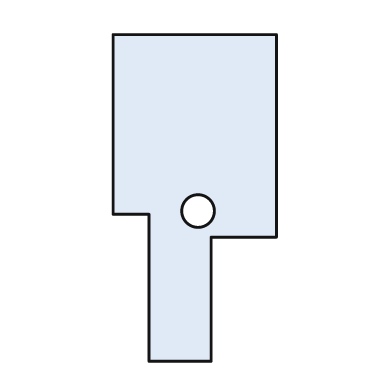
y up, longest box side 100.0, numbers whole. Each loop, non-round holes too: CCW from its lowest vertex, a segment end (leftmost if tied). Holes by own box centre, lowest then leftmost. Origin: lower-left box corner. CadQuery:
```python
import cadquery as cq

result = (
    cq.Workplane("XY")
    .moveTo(11.0, 0.0)
    .lineTo(30.0, 0.0)
    .lineTo(30.0, 38.0)
    .lineTo(50.0, 38.0)
    .lineTo(50.0, 100.0)
    .lineTo(0.0, 100.0)
    .lineTo(0.0, 45.0)
    .lineTo(11.0, 45.0)
    .close()
    .moveTo(26.0, 46.0)
    .circle(5.0)
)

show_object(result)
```